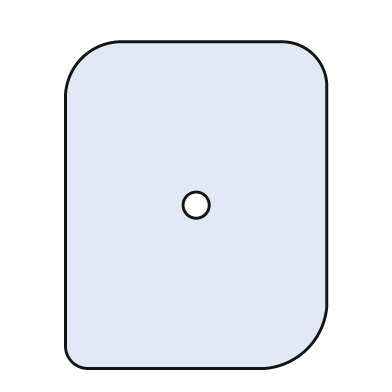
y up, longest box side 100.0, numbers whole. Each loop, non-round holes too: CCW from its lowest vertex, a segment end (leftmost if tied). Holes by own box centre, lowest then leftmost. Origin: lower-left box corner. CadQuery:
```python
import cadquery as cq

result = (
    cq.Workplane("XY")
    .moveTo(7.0, 0.0)
    .lineTo(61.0, 0.0)
    .threePointArc((74.0, 6.0), (80.0, 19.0))
    .lineTo(80.0, 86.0)
    .threePointArc((76.0, 96.0), (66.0, 100.0))
    .lineTo(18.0, 100.0)
    .threePointArc((5.0, 95.0), (0.0, 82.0))
    .lineTo(0.0, 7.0)
    .threePointArc((2.0, 2.0), (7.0, 0.0))
    .close()
    .moveTo(40.0, 50.0)
    .circle(4.0)
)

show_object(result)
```